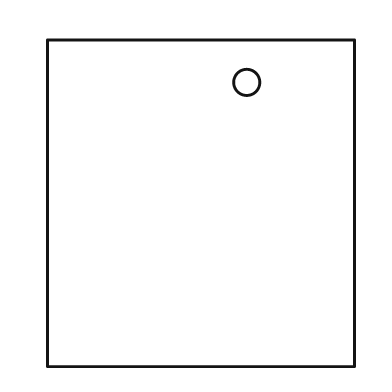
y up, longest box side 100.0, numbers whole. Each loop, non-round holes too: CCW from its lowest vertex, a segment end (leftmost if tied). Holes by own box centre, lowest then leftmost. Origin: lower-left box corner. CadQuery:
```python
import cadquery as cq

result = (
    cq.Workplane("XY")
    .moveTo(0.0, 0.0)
    .lineTo(94.0, 0.0)
    .lineTo(94.0, 100.0)
    .lineTo(0.0, 100.0)
    .close()
    .moveTo(61.0, 87.0)
    .circle(4.0)
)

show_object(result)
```